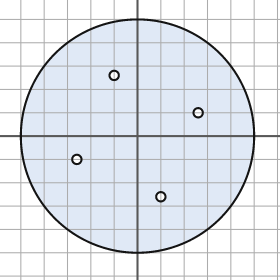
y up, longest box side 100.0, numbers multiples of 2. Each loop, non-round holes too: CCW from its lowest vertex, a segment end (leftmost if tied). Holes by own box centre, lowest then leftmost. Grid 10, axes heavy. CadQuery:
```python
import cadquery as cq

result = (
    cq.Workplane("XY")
    .moveTo(0.0, 0.0)
    .circle(50.0)
    .moveTo(10.0, -26.0)
    .circle(2.0)
    .moveTo(-26.0, -10.0)
    .circle(2.0)
    .moveTo(26.0, 10.0)
    .circle(2.0)
    .moveTo(-10.0, 26.0)
    .circle(2.0)
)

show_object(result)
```